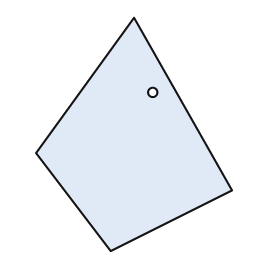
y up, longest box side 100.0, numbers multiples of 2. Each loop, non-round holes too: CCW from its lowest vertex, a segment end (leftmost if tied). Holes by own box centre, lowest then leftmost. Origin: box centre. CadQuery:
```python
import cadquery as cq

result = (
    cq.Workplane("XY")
    .moveTo(-10.0, -50.0)
    .lineTo(42.0, -24.0)
    .lineTo(0.0, 50.0)
    .lineTo(-42.0, -8.0)
    .close()
    .moveTo(8.0, 18.0)
    .circle(2.0)
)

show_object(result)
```